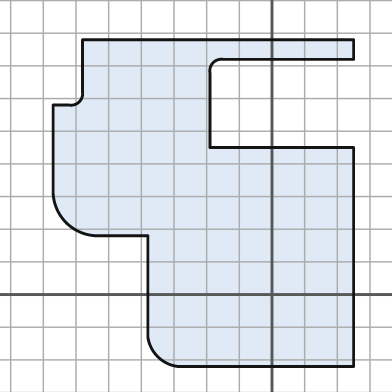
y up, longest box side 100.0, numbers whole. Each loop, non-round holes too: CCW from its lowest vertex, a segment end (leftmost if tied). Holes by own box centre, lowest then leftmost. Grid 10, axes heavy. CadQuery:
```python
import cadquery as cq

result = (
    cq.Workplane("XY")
    .moveTo(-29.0, -22.0)
    .lineTo(25.0, -22.0)
    .lineTo(25.0, 45.0)
    .lineTo(-19.0, 45.0)
    .lineTo(-19.0, 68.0)
    .threePointArc((-18.0, 71.0), (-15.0, 72.0))
    .lineTo(25.0, 72.0)
    .lineTo(25.0, 78.0)
    .lineTo(-58.0, 78.0)
    .lineTo(-58.0, 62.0)
    .threePointArc((-59.0, 59.0), (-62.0, 58.0))
    .lineTo(-67.0, 58.0)
    .lineTo(-67.0, 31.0)
    .threePointArc((-63.0, 22.0), (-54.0, 18.0))
    .lineTo(-38.0, 18.0)
    .lineTo(-38.0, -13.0)
    .threePointArc((-35.0, -19.0), (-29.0, -22.0))
    .close()
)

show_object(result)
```